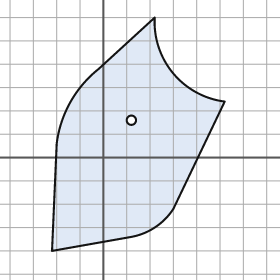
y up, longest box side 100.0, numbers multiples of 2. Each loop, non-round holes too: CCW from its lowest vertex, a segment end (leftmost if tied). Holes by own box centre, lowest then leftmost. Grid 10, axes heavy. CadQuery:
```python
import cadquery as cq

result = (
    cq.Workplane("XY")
    .moveTo(-22.0, -40.0)
    .lineTo(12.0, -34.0)
    .threePointArc((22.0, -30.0), (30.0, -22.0))
    .lineTo(52.0, 24.0)
    .threePointArc((30.0, 36.0), (22.0, 60.0))
    .lineTo(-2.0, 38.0)
    .threePointArc((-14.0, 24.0), (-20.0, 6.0))
    .close()
    .moveTo(12.0, 16.0)
    .circle(2.0)
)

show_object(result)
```